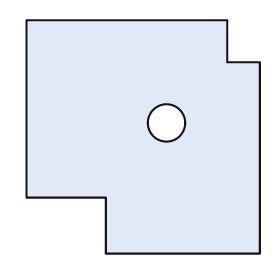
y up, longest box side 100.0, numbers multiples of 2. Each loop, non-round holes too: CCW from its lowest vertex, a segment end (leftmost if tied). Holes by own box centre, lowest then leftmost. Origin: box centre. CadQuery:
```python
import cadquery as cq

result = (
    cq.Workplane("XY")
    .moveTo(-16.0, -50.0)
    .lineTo(50.0, -50.0)
    .lineTo(50.0, 32.0)
    .lineTo(36.0, 32.0)
    .lineTo(36.0, 50.0)
    .lineTo(-50.0, 50.0)
    .lineTo(-50.0, -26.0)
    .lineTo(-16.0, -26.0)
    .close()
    .moveTo(10.0, 6.0)
    .circle(8.0)
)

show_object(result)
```